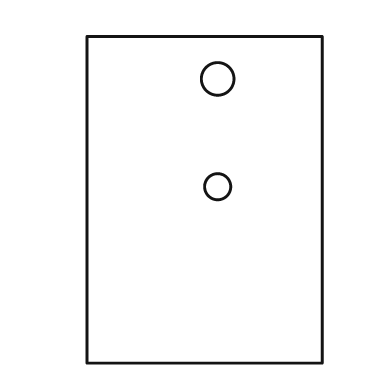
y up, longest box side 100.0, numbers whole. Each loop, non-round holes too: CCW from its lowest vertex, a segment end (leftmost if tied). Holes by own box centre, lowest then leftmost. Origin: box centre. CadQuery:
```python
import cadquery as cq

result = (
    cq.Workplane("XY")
    .moveTo(-36.0, -50.0)
    .lineTo(36.0, -50.0)
    .lineTo(36.0, 50.0)
    .lineTo(-36.0, 50.0)
    .close()
    .moveTo(4.0, 4.0)
    .circle(4.0)
    .moveTo(4.0, 37.0)
    .circle(5.0)
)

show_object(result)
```